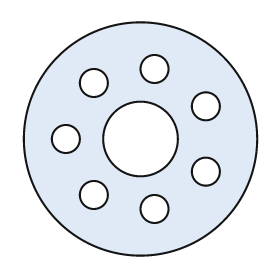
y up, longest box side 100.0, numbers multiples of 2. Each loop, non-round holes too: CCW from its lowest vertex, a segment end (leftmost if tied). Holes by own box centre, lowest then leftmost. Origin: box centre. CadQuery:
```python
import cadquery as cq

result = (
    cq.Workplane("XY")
    .moveTo(0.0, 0.0)
    .circle(50.0)
    .moveTo(6.0, -30.0)
    .circle(6.0)
    .moveTo(-20.0, -24.0)
    .circle(6.0)
    .moveTo(28.0, -14.0)
    .circle(6.0)
    .moveTo(-32.0, 0.0)
    .circle(6.0)
    .moveTo(0.0, 0.0)
    .circle(16.0)
    .moveTo(28.0, 14.0)
    .circle(6.0)
    .moveTo(-20.0, 24.0)
    .circle(6.0)
    .moveTo(6.0, 30.0)
    .circle(6.0)
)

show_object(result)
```